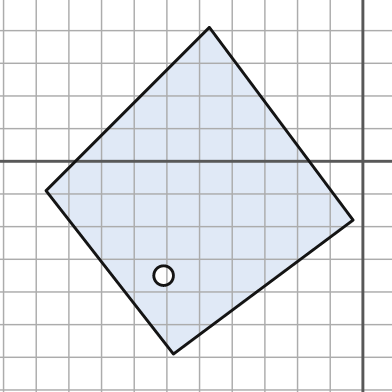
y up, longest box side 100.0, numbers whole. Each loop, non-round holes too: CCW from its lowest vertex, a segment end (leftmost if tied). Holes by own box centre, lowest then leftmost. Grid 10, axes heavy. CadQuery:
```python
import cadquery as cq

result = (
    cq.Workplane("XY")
    .moveTo(-58.0, -59.0)
    .lineTo(-3.0, -18.0)
    .lineTo(-47.0, 41.0)
    .lineTo(-97.0, -9.0)
    .close()
    .moveTo(-61.0, -35.0)
    .circle(3.0)
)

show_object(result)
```